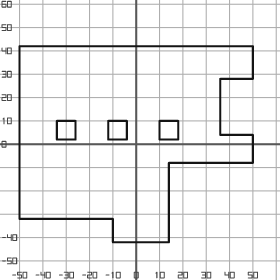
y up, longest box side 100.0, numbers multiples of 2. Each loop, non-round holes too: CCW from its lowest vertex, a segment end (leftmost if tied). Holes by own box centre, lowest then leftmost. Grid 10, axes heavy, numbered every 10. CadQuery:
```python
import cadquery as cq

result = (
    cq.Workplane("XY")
    .moveTo(-10.0, -42.0)
    .lineTo(14.0, -42.0)
    .lineTo(14.0, -8.0)
    .lineTo(50.0, -8.0)
    .lineTo(50.0, 4.0)
    .lineTo(36.0, 4.0)
    .lineTo(36.0, 28.0)
    .lineTo(50.0, 28.0)
    .lineTo(50.0, 42.0)
    .lineTo(-50.0, 42.0)
    .lineTo(-50.0, -32.0)
    .lineTo(-10.0, -32.0)
    .close()
    .moveTo(-34.0, 2.0)
    .lineTo(-26.0, 2.0)
    .lineTo(-26.0, 10.0)
    .lineTo(-34.0, 10.0)
    .close()
    .moveTo(-12.0, 2.0)
    .lineTo(-4.0, 2.0)
    .lineTo(-4.0, 10.0)
    .lineTo(-12.0, 10.0)
    .close()
    .moveTo(10.0, 2.0)
    .lineTo(18.0, 2.0)
    .lineTo(18.0, 10.0)
    .lineTo(10.0, 10.0)
    .close()
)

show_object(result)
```